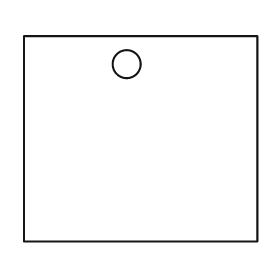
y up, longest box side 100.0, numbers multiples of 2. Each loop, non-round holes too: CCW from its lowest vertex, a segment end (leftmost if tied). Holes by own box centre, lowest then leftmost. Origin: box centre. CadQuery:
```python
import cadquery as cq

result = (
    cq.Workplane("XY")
    .moveTo(-50.0, -44.0)
    .lineTo(50.0, -44.0)
    .lineTo(50.0, 44.0)
    .lineTo(-50.0, 44.0)
    .close()
    .moveTo(-6.0, 32.0)
    .circle(6.0)
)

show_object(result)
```